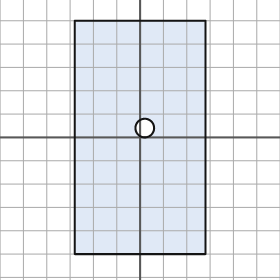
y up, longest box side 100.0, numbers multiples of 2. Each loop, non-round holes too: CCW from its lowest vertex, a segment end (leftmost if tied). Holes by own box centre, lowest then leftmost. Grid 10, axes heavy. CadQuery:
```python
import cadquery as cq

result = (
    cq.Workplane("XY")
    .moveTo(-28.0, -50.0)
    .lineTo(28.0, -50.0)
    .lineTo(28.0, 50.0)
    .lineTo(-28.0, 50.0)
    .close()
    .moveTo(2.0, 4.0)
    .circle(4.0)
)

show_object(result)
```